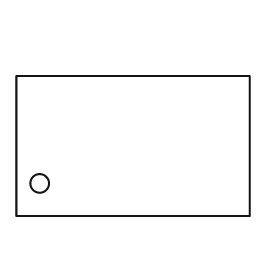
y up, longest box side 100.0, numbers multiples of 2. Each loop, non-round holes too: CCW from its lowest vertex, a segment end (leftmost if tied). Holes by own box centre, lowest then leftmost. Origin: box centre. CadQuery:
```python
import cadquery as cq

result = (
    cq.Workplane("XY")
    .moveTo(-50.0, -30.0)
    .lineTo(50.0, -30.0)
    .lineTo(50.0, 30.0)
    .lineTo(-50.0, 30.0)
    .close()
    .moveTo(-40.0, -16.0)
    .circle(4.0)
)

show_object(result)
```